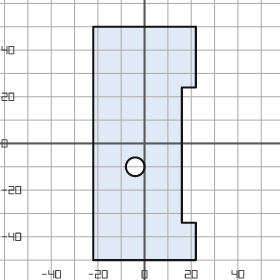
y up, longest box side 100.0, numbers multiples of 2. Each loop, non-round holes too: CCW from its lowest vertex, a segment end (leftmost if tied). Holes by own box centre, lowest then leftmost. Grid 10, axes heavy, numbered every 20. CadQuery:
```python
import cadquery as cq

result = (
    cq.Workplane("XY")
    .moveTo(-22.0, -50.0)
    .lineTo(22.0, -50.0)
    .lineTo(22.0, -34.0)
    .lineTo(16.0, -34.0)
    .lineTo(16.0, 24.0)
    .lineTo(22.0, 24.0)
    .lineTo(22.0, 50.0)
    .lineTo(-22.0, 50.0)
    .close()
    .moveTo(-4.0, -10.0)
    .circle(4.0)
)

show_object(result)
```